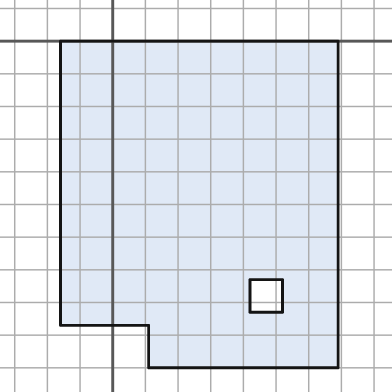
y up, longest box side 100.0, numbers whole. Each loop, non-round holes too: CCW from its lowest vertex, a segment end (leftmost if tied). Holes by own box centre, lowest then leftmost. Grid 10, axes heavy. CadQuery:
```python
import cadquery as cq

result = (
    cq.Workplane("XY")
    .moveTo(11.0, -100.0)
    .lineTo(69.0, -100.0)
    .lineTo(69.0, 0.0)
    .lineTo(-16.0, 0.0)
    .lineTo(-16.0, -87.0)
    .lineTo(11.0, -87.0)
    .close()
    .moveTo(42.0, -83.0)
    .lineTo(52.0, -83.0)
    .lineTo(52.0, -73.0)
    .lineTo(42.0, -73.0)
    .close()
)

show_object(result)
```